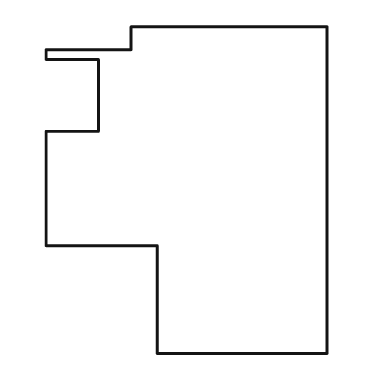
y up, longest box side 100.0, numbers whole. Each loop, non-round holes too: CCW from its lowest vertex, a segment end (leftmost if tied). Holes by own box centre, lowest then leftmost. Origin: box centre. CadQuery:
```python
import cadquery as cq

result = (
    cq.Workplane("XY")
    .moveTo(-9.0, -50.0)
    .lineTo(43.0, -50.0)
    .lineTo(43.0, 50.0)
    .lineTo(-17.0, 50.0)
    .lineTo(-17.0, 43.0)
    .lineTo(-43.0, 43.0)
    .lineTo(-43.0, 40.0)
    .lineTo(-27.0, 40.0)
    .lineTo(-27.0, 18.0)
    .lineTo(-43.0, 18.0)
    .lineTo(-43.0, -17.0)
    .lineTo(-9.0, -17.0)
    .close()
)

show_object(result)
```